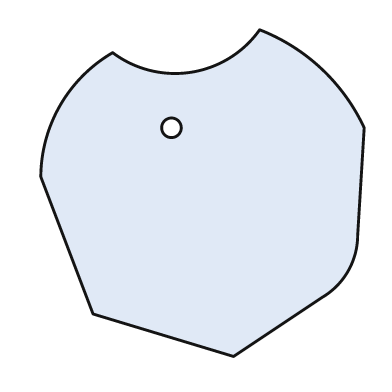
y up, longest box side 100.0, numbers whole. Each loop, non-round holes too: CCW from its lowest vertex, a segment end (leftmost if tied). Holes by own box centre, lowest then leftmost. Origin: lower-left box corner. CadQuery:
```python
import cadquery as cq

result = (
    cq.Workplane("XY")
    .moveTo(59.0, 0.0)
    .lineTo(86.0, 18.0)
    .threePointArc((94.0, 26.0), (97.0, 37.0))
    .lineTo(99.0, 70.0)
    .threePointArc((86.0, 88.0), (67.0, 100.0))
    .threePointArc((46.0, 87.0), (22.0, 93.0))
    .threePointArc((6.0, 77.0), (0.0, 55.0))
    .lineTo(16.0, 13.0)
    .close()
    .moveTo(40.0, 70.0)
    .circle(3.0)
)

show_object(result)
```